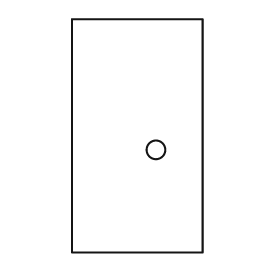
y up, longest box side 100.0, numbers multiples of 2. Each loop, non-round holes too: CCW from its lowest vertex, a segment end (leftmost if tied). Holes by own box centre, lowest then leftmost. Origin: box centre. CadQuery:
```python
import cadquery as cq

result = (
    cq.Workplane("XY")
    .moveTo(-28.0, -50.0)
    .lineTo(28.0, -50.0)
    .lineTo(28.0, 50.0)
    .lineTo(-28.0, 50.0)
    .close()
    .moveTo(8.0, -6.0)
    .circle(4.0)
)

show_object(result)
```